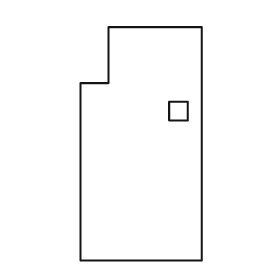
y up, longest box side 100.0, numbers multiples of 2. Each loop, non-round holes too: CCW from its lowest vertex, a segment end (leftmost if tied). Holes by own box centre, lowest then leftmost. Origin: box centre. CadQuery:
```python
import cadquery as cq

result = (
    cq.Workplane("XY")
    .moveTo(-26.0, -50.0)
    .lineTo(26.0, -50.0)
    .lineTo(26.0, 50.0)
    .lineTo(-14.0, 50.0)
    .lineTo(-14.0, 26.0)
    .lineTo(-26.0, 26.0)
    .close()
    .moveTo(12.0, 10.0)
    .lineTo(20.0, 10.0)
    .lineTo(20.0, 18.0)
    .lineTo(12.0, 18.0)
    .close()
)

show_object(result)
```